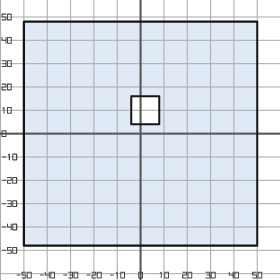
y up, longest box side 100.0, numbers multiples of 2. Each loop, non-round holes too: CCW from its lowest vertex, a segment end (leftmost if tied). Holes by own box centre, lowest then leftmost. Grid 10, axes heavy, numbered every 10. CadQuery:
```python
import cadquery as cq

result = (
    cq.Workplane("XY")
    .moveTo(-50.0, -48.0)
    .lineTo(50.0, -48.0)
    .lineTo(50.0, 48.0)
    .lineTo(-50.0, 48.0)
    .close()
    .moveTo(-4.0, 4.0)
    .lineTo(8.0, 4.0)
    .lineTo(8.0, 16.0)
    .lineTo(-4.0, 16.0)
    .close()
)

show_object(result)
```